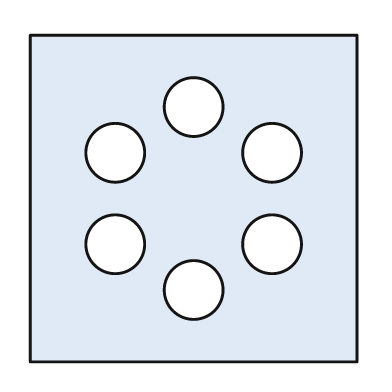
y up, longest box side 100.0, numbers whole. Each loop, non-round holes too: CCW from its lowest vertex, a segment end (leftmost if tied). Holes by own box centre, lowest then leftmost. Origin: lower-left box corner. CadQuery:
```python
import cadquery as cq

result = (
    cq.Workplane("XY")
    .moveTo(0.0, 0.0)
    .lineTo(100.0, 0.0)
    .lineTo(100.0, 100.0)
    .lineTo(0.0, 100.0)
    .close()
    .moveTo(50.0, 22.0)
    .circle(9.0)
    .moveTo(26.0, 36.0)
    .circle(9.0)
    .moveTo(74.0, 36.0)
    .circle(9.0)
    .moveTo(26.0, 64.0)
    .circle(9.0)
    .moveTo(74.0, 64.0)
    .circle(9.0)
    .moveTo(50.0, 78.0)
    .circle(9.0)
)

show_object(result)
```